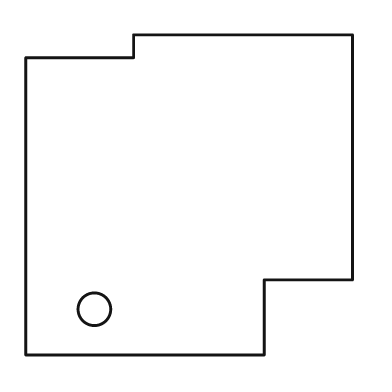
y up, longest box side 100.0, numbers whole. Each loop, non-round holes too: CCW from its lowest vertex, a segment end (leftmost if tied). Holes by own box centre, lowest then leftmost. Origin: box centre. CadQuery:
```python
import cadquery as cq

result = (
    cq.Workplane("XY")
    .moveTo(-50.0, -49.0)
    .lineTo(23.0, -49.0)
    .lineTo(23.0, -26.0)
    .lineTo(50.0, -26.0)
    .lineTo(50.0, 49.0)
    .lineTo(-17.0, 49.0)
    .lineTo(-17.0, 42.0)
    .lineTo(-50.0, 42.0)
    .close()
    .moveTo(-29.0, -35.0)
    .circle(5.0)
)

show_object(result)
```